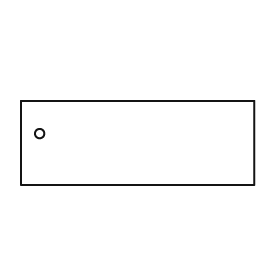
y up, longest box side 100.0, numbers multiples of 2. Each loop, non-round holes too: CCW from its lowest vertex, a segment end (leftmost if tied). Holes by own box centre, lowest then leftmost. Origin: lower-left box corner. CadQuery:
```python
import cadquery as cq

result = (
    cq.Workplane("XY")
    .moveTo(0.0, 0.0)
    .lineTo(100.0, 0.0)
    .lineTo(100.0, 36.0)
    .lineTo(0.0, 36.0)
    .close()
    .moveTo(8.0, 22.0)
    .circle(2.0)
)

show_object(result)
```